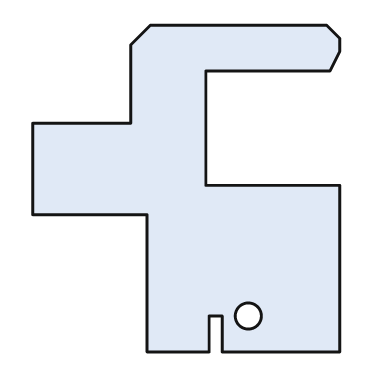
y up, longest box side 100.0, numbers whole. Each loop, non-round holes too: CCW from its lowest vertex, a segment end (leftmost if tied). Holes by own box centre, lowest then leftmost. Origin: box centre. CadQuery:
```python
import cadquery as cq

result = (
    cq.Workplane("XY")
    .moveTo(-12.0, -50.0)
    .lineTo(7.0, -50.0)
    .lineTo(7.0, -39.0)
    .lineTo(11.0, -39.0)
    .lineTo(11.0, -50.0)
    .lineTo(47.0, -50.0)
    .lineTo(47.0, 1.0)
    .lineTo(6.0, 1.0)
    .lineTo(6.0, 36.0)
    .lineTo(44.0, 36.0)
    .lineTo(47.0, 42.0)
    .lineTo(47.0, 46.0)
    .lineTo(43.0, 50.0)
    .lineTo(-11.0, 50.0)
    .lineTo(-17.0, 44.0)
    .lineTo(-17.0, 20.0)
    .lineTo(-47.0, 20.0)
    .lineTo(-47.0, -8.0)
    .lineTo(-12.0, -8.0)
    .close()
    .moveTo(19.0, -39.0)
    .circle(4.0)
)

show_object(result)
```